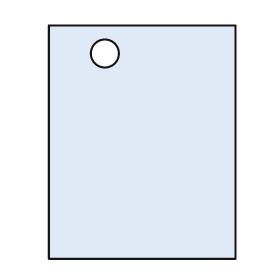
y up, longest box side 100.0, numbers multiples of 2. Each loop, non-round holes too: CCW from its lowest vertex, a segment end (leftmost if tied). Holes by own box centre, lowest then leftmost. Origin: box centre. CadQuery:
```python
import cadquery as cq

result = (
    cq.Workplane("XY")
    .moveTo(-40.0, -50.0)
    .lineTo(40.0, -50.0)
    .lineTo(40.0, 50.0)
    .lineTo(-40.0, 50.0)
    .close()
    .moveTo(-16.0, 38.0)
    .circle(6.0)
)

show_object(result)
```